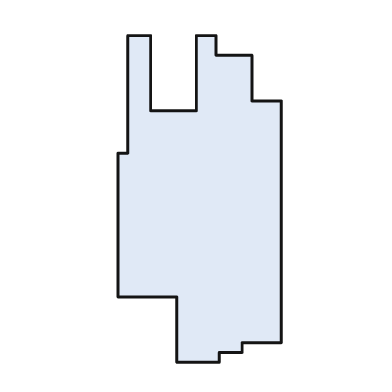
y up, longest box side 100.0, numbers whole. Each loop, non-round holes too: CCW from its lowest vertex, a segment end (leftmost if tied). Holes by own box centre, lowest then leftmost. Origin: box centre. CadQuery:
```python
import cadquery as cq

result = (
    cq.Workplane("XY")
    .moveTo(-7.0, -50.0)
    .lineTo(6.0, -50.0)
    .lineTo(6.0, -47.0)
    .lineTo(13.0, -47.0)
    .lineTo(13.0, -44.0)
    .lineTo(25.0, -44.0)
    .lineTo(25.0, 30.0)
    .lineTo(16.0, 30.0)
    .lineTo(16.0, 44.0)
    .lineTo(5.0, 44.0)
    .lineTo(5.0, 50.0)
    .lineTo(-1.0, 50.0)
    .lineTo(-1.0, 27.0)
    .lineTo(-15.0, 27.0)
    .lineTo(-15.0, 50.0)
    .lineTo(-22.0, 50.0)
    .lineTo(-22.0, 14.0)
    .lineTo(-25.0, 14.0)
    .lineTo(-25.0, -30.0)
    .lineTo(-7.0, -30.0)
    .close()
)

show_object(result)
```